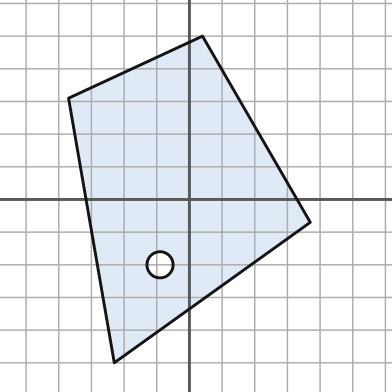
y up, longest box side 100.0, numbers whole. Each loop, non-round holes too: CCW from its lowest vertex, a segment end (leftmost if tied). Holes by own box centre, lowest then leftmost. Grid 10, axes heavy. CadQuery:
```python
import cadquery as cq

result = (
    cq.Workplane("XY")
    .moveTo(-23.0, -50.0)
    .lineTo(37.0, -7.0)
    .lineTo(4.0, 50.0)
    .lineTo(-37.0, 31.0)
    .close()
    .moveTo(-9.0, -20.0)
    .circle(4.0)
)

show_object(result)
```